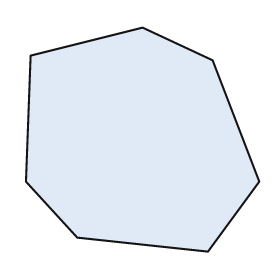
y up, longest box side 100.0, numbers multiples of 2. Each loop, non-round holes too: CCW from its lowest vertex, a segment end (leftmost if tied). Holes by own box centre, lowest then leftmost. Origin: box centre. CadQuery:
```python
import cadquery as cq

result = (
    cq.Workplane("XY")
    .moveTo(28.0, -48.0)
    .lineTo(50.0, -18.0)
    .lineTo(30.0, 34.0)
    .lineTo(0.0, 48.0)
    .lineTo(-48.0, 36.0)
    .lineTo(-50.0, -18.0)
    .lineTo(-28.0, -42.0)
    .close()
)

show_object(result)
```